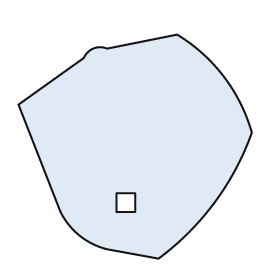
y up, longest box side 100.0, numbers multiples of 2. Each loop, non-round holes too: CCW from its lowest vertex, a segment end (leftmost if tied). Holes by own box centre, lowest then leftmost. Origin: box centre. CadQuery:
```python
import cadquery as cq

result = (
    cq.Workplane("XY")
    .moveTo(10.0, -48.0)
    .threePointArc((34.0, -24.0), (50.0, 6.0))
    .threePointArc((38.0, 30.0), (18.0, 48.0))
    .lineTo(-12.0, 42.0)
    .threePointArc((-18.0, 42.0), (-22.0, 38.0))
    .lineTo(-50.0, 18.0)
    .lineTo(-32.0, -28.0)
    .threePointArc((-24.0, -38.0), (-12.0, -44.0))
    .close()
    .moveTo(-8.0, -28.0)
    .lineTo(0.0, -28.0)
    .lineTo(0.0, -20.0)
    .lineTo(-8.0, -20.0)
    .close()
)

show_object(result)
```